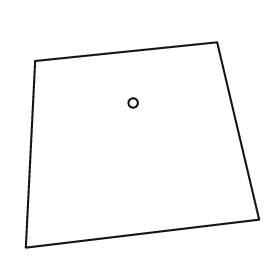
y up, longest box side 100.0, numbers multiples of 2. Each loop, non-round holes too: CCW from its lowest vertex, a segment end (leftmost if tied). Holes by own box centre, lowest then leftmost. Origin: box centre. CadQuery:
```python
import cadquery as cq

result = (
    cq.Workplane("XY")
    .moveTo(-50.0, -44.0)
    .lineTo(50.0, -32.0)
    .lineTo(32.0, 44.0)
    .lineTo(-46.0, 36.0)
    .close()
    .moveTo(-4.0, 18.0)
    .circle(2.0)
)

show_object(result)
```